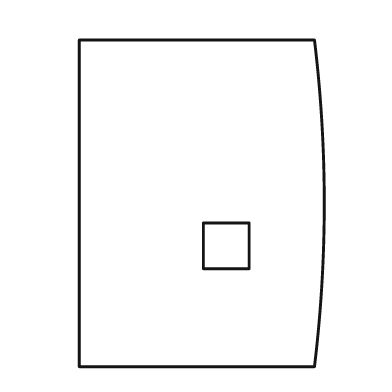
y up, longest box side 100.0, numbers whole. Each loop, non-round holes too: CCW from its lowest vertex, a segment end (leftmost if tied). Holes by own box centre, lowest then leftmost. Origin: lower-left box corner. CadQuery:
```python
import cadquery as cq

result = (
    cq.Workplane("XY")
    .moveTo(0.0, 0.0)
    .lineTo(72.0, 0.0)
    .threePointArc((75.0, 50.0), (72.0, 100.0))
    .lineTo(0.0, 100.0)
    .close()
    .moveTo(38.0, 30.0)
    .lineTo(52.0, 30.0)
    .lineTo(52.0, 44.0)
    .lineTo(38.0, 44.0)
    .close()
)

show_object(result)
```